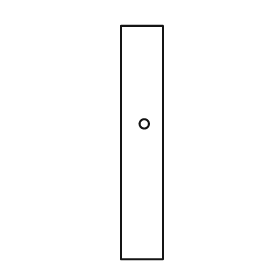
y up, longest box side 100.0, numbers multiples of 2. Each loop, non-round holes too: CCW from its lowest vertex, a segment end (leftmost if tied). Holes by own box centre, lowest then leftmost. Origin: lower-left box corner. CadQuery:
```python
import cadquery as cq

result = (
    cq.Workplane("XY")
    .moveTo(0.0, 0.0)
    .lineTo(18.0, 0.0)
    .lineTo(18.0, 100.0)
    .lineTo(0.0, 100.0)
    .close()
    .moveTo(10.0, 58.0)
    .circle(2.0)
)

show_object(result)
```